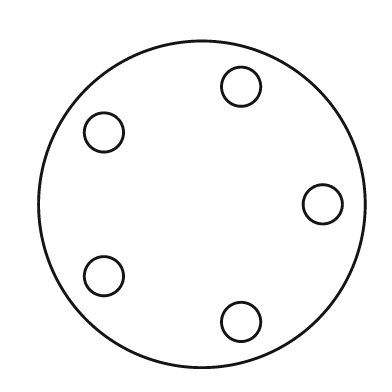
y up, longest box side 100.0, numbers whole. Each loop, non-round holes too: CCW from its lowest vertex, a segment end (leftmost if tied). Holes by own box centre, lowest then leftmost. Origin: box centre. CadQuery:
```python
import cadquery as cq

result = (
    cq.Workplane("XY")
    .moveTo(0.0, 0.0)
    .circle(50.0)
    .moveTo(12.0, -36.0)
    .circle(6.0)
    .moveTo(-30.0, -22.0)
    .circle(6.0)
    .moveTo(37.0, 0.0)
    .circle(6.0)
    .moveTo(-30.0, 22.0)
    .circle(6.0)
    .moveTo(12.0, 36.0)
    .circle(6.0)
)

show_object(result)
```